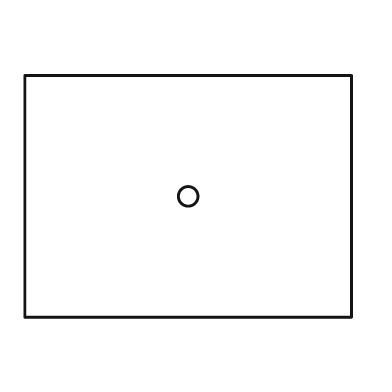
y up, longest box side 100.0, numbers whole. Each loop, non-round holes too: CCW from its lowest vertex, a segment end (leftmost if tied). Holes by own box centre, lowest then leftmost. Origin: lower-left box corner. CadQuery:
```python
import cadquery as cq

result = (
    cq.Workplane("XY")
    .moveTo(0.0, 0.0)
    .lineTo(100.0, 0.0)
    .lineTo(100.0, 74.0)
    .lineTo(0.0, 74.0)
    .close()
    .moveTo(50.0, 37.0)
    .circle(3.0)
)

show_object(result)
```